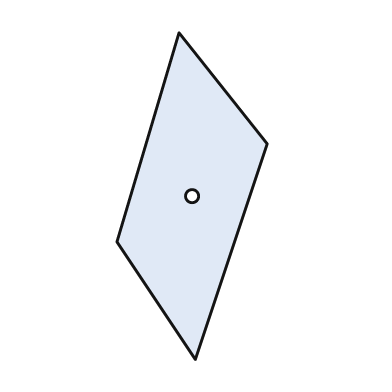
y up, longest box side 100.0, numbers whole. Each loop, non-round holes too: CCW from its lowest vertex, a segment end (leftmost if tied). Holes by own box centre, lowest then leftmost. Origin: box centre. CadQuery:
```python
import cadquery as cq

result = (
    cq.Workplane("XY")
    .moveTo(1.0, -50.0)
    .lineTo(23.0, 16.0)
    .lineTo(-4.0, 50.0)
    .lineTo(-23.0, -14.0)
    .close()
    .moveTo(0.0, 0.0)
    .circle(2.0)
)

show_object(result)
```